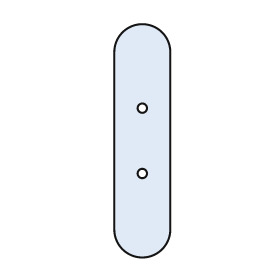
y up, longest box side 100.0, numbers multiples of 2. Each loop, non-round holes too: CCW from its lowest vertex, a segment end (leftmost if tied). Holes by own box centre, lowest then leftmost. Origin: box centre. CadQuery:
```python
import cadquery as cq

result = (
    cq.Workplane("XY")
    .moveTo(-12.0, -38.0)
    .threePointArc((0.0, -50.0), (12.0, -38.0))
    .lineTo(12.0, 38.0)
    .threePointArc((0.0, 50.0), (-12.0, 38.0))
    .close()
    .moveTo(0.0, -14.0)
    .circle(2.0)
    .moveTo(0.0, 14.0)
    .circle(2.0)
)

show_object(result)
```